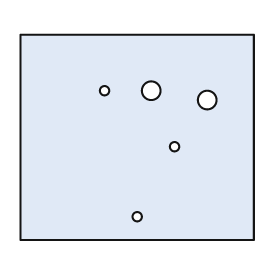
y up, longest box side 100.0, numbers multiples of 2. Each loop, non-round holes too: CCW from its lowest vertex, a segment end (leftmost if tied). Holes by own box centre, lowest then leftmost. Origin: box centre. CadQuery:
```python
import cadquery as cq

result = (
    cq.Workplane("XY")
    .moveTo(-50.0, -44.0)
    .lineTo(50.0, -44.0)
    .lineTo(50.0, 44.0)
    .lineTo(-50.0, 44.0)
    .close()
    .moveTo(0.0, -34.0)
    .circle(2.0)
    .moveTo(16.0, -4.0)
    .circle(2.0)
    .moveTo(30.0, 16.0)
    .circle(4.0)
    .moveTo(-14.0, 20.0)
    .circle(2.0)
    .moveTo(6.0, 20.0)
    .circle(4.0)
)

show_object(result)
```